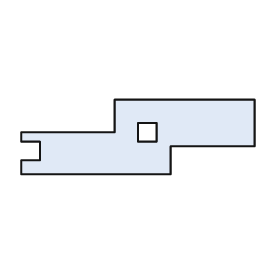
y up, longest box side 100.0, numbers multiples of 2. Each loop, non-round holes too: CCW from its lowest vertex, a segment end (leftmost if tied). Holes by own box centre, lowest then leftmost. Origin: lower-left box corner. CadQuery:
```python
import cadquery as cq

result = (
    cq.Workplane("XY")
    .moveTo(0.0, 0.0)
    .lineTo(64.0, 0.0)
    .lineTo(64.0, 12.0)
    .lineTo(100.0, 12.0)
    .lineTo(100.0, 32.0)
    .lineTo(40.0, 32.0)
    .lineTo(40.0, 18.0)
    .lineTo(0.0, 18.0)
    .lineTo(0.0, 14.0)
    .lineTo(8.0, 14.0)
    .lineTo(8.0, 6.0)
    .lineTo(0.0, 6.0)
    .close()
    .moveTo(50.0, 14.0)
    .lineTo(58.0, 14.0)
    .lineTo(58.0, 22.0)
    .lineTo(50.0, 22.0)
    .close()
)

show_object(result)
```